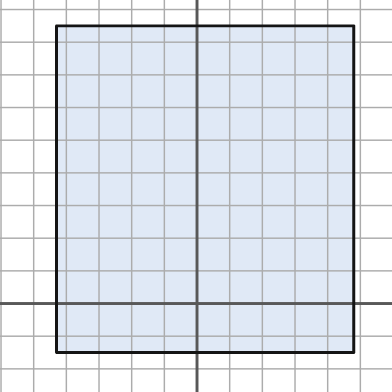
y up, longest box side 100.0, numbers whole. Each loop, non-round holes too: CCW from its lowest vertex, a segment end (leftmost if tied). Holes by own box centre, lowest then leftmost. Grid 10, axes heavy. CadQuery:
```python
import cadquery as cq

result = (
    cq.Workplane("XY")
    .moveTo(-43.0, -15.0)
    .lineTo(48.0, -15.0)
    .lineTo(48.0, 85.0)
    .lineTo(-43.0, 85.0)
    .close()
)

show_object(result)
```